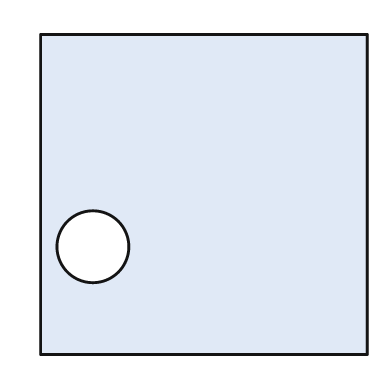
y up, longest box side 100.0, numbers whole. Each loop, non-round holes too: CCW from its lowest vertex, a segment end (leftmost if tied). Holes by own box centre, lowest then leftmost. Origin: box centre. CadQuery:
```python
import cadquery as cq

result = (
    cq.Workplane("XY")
    .moveTo(-50.0, -49.0)
    .lineTo(50.0, -49.0)
    .lineTo(50.0, 49.0)
    .lineTo(-50.0, 49.0)
    .close()
    .moveTo(-34.0, -16.0)
    .circle(11.0)
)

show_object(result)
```